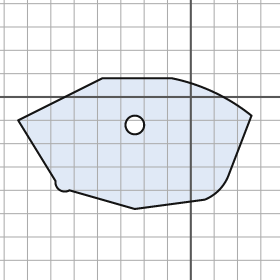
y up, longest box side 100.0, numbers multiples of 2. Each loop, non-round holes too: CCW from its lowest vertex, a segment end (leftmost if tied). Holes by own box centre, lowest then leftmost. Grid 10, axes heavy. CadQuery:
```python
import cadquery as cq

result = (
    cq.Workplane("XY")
    .moveTo(-24.0, -48.0)
    .lineTo(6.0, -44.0)
    .threePointArc((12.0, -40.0), (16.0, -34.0))
    .lineTo(26.0, -8.0)
    .threePointArc((10.0, 2.0), (-8.0, 8.0))
    .lineTo(-38.0, 8.0)
    .lineTo(-74.0, -10.0)
    .lineTo(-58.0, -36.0)
    .threePointArc((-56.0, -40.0), (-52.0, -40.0))
    .close()
    .moveTo(-24.0, -12.0)
    .circle(4.0)
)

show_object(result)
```